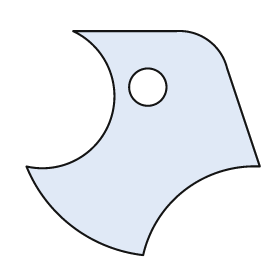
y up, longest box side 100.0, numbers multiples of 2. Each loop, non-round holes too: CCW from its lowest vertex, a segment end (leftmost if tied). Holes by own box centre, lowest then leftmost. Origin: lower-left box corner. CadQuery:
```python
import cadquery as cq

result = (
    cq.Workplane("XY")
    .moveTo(50.0, 0.0)
    .threePointArc((68.0, 28.0), (100.0, 38.0))
    .lineTo(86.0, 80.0)
    .threePointArc((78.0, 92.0), (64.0, 96.0))
    .lineTo(20.0, 96.0)
    .threePointArc((36.0, 58.0), (0.0, 38.0))
    .threePointArc((20.0, 12.0), (50.0, 0.0))
    .close()
    .moveTo(52.0, 72.0)
    .circle(8.0)
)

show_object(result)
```